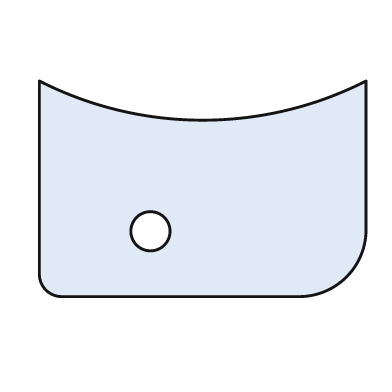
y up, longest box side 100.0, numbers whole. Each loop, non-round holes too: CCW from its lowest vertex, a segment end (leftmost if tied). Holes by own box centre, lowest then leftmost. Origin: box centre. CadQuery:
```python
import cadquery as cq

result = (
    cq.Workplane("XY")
    .moveTo(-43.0, -33.0)
    .lineTo(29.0, -33.0)
    .threePointArc((44.0, -27.0), (50.0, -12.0))
    .lineTo(50.0, 33.0)
    .threePointArc((0.0, 21.0), (-50.0, 33.0))
    .lineTo(-50.0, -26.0)
    .threePointArc((-48.0, -31.0), (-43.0, -33.0))
    .close()
    .moveTo(-16.0, -13.0)
    .circle(6.0)
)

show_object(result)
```